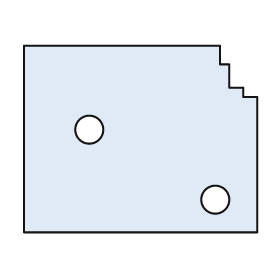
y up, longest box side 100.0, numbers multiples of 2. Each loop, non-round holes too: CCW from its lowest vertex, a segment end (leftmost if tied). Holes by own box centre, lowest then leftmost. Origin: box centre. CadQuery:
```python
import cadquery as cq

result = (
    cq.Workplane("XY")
    .moveTo(-50.0, -40.0)
    .lineTo(50.0, -40.0)
    .lineTo(50.0, 18.0)
    .lineTo(44.0, 18.0)
    .lineTo(44.0, 22.0)
    .lineTo(38.0, 22.0)
    .lineTo(38.0, 32.0)
    .lineTo(34.0, 32.0)
    .lineTo(34.0, 40.0)
    .lineTo(-50.0, 40.0)
    .close()
    .moveTo(32.0, -26.0)
    .circle(6.0)
    .moveTo(-22.0, 4.0)
    .circle(6.0)
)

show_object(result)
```